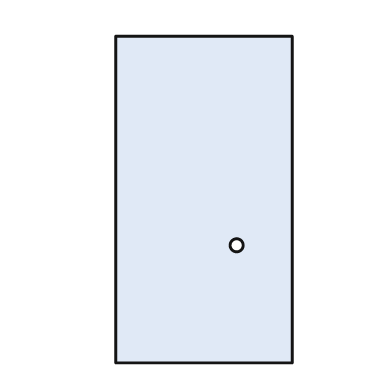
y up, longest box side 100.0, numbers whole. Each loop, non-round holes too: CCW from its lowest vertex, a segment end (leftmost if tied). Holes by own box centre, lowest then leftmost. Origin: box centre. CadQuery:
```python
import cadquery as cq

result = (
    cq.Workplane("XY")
    .moveTo(-27.0, -50.0)
    .lineTo(27.0, -50.0)
    .lineTo(27.0, 50.0)
    .lineTo(-27.0, 50.0)
    .close()
    .moveTo(10.0, -14.0)
    .circle(2.0)
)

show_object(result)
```